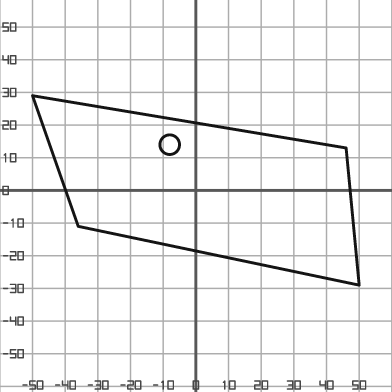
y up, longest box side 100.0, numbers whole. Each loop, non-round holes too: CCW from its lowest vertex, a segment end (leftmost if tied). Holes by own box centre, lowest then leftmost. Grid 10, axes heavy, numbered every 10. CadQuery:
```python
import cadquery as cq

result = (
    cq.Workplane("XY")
    .moveTo(50.0, -29.0)
    .lineTo(46.0, 13.0)
    .lineTo(-50.0, 29.0)
    .lineTo(-36.0, -11.0)
    .close()
    .moveTo(-8.0, 14.0)
    .circle(3.0)
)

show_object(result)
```